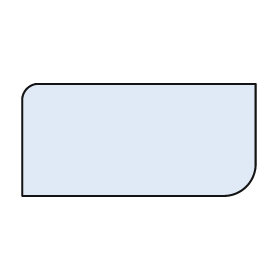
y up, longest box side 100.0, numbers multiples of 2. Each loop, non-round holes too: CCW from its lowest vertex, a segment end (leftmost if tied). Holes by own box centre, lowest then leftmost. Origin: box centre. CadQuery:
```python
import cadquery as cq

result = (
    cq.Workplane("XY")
    .moveTo(-50.0, -24.0)
    .lineTo(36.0, -24.0)
    .threePointArc((46.0, -20.0), (50.0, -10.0))
    .lineTo(50.0, 24.0)
    .lineTo(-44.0, 24.0)
    .threePointArc((-48.0, 22.0), (-50.0, 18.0))
    .close()
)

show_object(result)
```